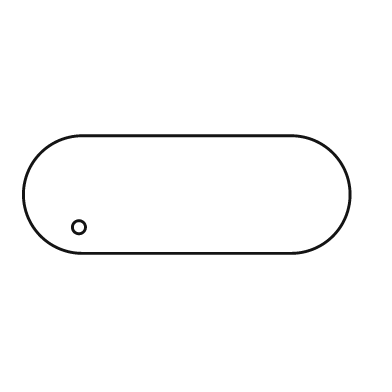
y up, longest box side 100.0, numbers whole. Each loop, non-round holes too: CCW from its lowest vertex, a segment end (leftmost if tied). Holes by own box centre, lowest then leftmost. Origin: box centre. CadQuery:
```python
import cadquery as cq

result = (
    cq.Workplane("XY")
    .moveTo(-32.0, -18.0)
    .lineTo(32.0, -18.0)
    .threePointArc((50.0, 0.0), (32.0, 18.0))
    .lineTo(-32.0, 18.0)
    .threePointArc((-50.0, 0.0), (-32.0, -18.0))
    .close()
    .moveTo(-33.0, -10.0)
    .circle(2.0)
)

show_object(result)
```